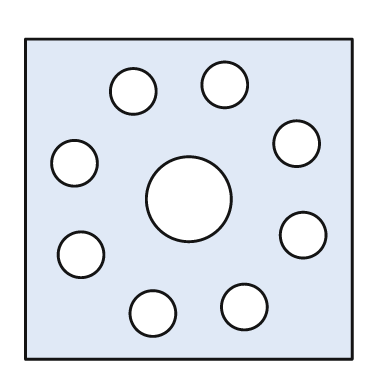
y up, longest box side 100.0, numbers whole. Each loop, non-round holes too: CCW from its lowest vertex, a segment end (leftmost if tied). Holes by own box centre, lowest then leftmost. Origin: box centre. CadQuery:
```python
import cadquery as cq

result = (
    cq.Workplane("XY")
    .moveTo(-50.0, -49.0)
    .lineTo(50.0, -49.0)
    .lineTo(50.0, 49.0)
    .lineTo(-50.0, 49.0)
    .close()
    .moveTo(-11.0, -35.0)
    .circle(7.0)
    .moveTo(17.0, -33.0)
    .circle(7.0)
    .moveTo(-33.0, -17.0)
    .circle(7.0)
    .moveTo(35.0, -11.0)
    .circle(7.0)
    .moveTo(0.0, 0.0)
    .circle(13.0)
    .moveTo(-35.0, 11.0)
    .circle(7.0)
    .moveTo(33.0, 17.0)
    .circle(7.0)
    .moveTo(-17.0, 33.0)
    .circle(7.0)
    .moveTo(11.0, 35.0)
    .circle(7.0)
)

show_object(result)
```